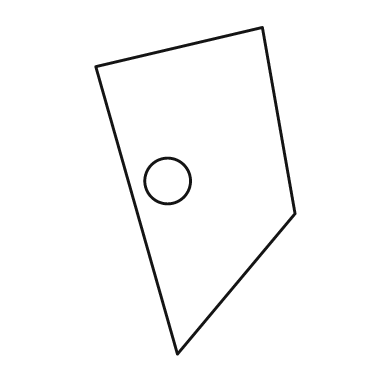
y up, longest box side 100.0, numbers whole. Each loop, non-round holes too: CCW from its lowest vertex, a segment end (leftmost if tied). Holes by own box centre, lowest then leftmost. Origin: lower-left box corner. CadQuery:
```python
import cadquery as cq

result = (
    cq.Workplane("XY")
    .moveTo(25.0, 0.0)
    .lineTo(61.0, 43.0)
    .lineTo(51.0, 100.0)
    .lineTo(0.0, 88.0)
    .close()
    .moveTo(22.0, 53.0)
    .circle(7.0)
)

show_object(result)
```